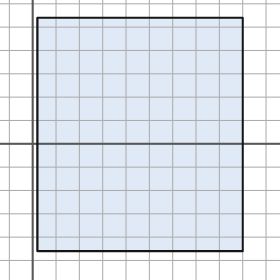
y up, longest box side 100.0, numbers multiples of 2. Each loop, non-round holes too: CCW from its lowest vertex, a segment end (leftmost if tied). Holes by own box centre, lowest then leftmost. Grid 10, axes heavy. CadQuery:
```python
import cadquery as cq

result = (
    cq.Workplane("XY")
    .moveTo(2.0, -46.0)
    .lineTo(90.0, -46.0)
    .lineTo(90.0, 54.0)
    .lineTo(2.0, 54.0)
    .close()
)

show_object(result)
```